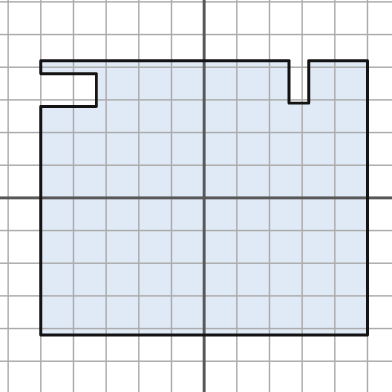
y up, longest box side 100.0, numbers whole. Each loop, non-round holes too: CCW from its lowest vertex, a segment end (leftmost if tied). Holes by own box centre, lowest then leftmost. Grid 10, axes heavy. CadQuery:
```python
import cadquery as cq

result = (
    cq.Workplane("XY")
    .moveTo(-50.0, -42.0)
    .lineTo(50.0, -42.0)
    .lineTo(50.0, 42.0)
    .lineTo(32.0, 42.0)
    .lineTo(32.0, 29.0)
    .lineTo(26.0, 29.0)
    .lineTo(26.0, 42.0)
    .lineTo(-50.0, 42.0)
    .lineTo(-50.0, 38.0)
    .lineTo(-33.0, 38.0)
    .lineTo(-33.0, 28.0)
    .lineTo(-50.0, 28.0)
    .close()
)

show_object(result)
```